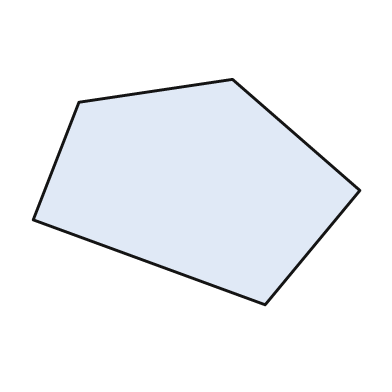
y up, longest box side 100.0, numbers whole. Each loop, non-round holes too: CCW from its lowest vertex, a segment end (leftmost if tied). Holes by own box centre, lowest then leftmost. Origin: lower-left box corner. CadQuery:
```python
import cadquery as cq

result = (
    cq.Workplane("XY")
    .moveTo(71.0, 0.0)
    .lineTo(100.0, 35.0)
    .lineTo(61.0, 69.0)
    .lineTo(14.0, 62.0)
    .lineTo(0.0, 26.0)
    .close()
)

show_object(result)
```